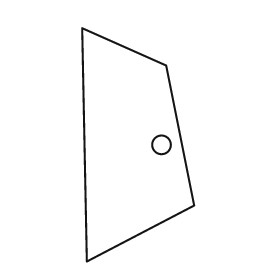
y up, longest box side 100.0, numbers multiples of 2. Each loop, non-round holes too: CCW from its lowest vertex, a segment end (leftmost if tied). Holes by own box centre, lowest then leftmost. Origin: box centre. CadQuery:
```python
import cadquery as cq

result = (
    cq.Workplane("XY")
    .moveTo(-22.0, -50.0)
    .lineTo(24.0, -26.0)
    .lineTo(12.0, 34.0)
    .lineTo(-24.0, 50.0)
    .close()
    .moveTo(10.0, 0.0)
    .circle(4.0)
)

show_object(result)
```